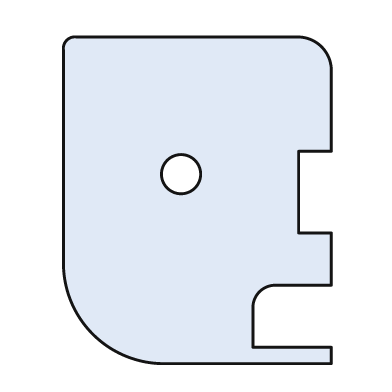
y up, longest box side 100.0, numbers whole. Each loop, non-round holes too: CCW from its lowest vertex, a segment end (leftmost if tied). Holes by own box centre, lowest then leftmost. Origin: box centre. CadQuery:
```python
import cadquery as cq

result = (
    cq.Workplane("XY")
    .moveTo(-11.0, -50.0)
    .lineTo(41.0, -50.0)
    .lineTo(41.0, -45.0)
    .lineTo(17.0, -45.0)
    .lineTo(17.0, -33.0)
    .threePointArc((19.0, -28.0), (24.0, -26.0))
    .lineTo(41.0, -26.0)
    .lineTo(41.0, -10.0)
    .lineTo(31.0, -10.0)
    .lineTo(31.0, 15.0)
    .lineTo(41.0, 15.0)
    .lineTo(41.0, 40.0)
    .threePointArc((38.0, 47.0), (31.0, 50.0))
    .lineTo(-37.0, 50.0)
    .threePointArc((-40.0, 49.0), (-41.0, 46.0))
    .lineTo(-41.0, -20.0)
    .threePointArc((-32.0, -41.0), (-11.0, -50.0))
    .close()
    .moveTo(-5.0, 8.0)
    .circle(6.0)
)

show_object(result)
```